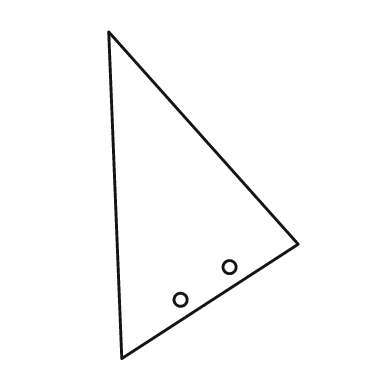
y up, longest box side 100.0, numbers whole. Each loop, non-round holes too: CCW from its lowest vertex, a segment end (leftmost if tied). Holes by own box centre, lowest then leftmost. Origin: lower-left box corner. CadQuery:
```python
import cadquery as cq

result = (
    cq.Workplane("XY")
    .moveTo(4.0, 0.0)
    .lineTo(58.0, 35.0)
    .lineTo(0.0, 100.0)
    .close()
    .moveTo(22.0, 18.0)
    .circle(2.0)
    .moveTo(37.0, 28.0)
    .circle(2.0)
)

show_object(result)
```